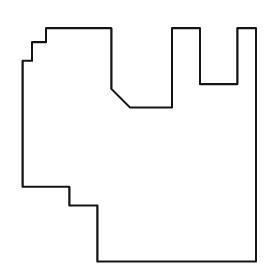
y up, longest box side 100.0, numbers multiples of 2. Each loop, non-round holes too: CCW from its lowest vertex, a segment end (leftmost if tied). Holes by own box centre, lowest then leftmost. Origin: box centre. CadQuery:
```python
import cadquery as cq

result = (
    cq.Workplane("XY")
    .moveTo(-18.0, -50.0)
    .lineTo(50.0, -50.0)
    .lineTo(50.0, 50.0)
    .lineTo(42.0, 50.0)
    .lineTo(42.0, 26.0)
    .lineTo(26.0, 26.0)
    .lineTo(26.0, 50.0)
    .lineTo(14.0, 50.0)
    .lineTo(14.0, 16.0)
    .lineTo(-4.0, 16.0)
    .lineTo(-12.0, 24.0)
    .lineTo(-12.0, 50.0)
    .lineTo(-40.0, 50.0)
    .lineTo(-40.0, 44.0)
    .lineTo(-46.0, 44.0)
    .lineTo(-46.0, 36.0)
    .lineTo(-50.0, 36.0)
    .lineTo(-50.0, -18.0)
    .lineTo(-30.0, -18.0)
    .lineTo(-30.0, -26.0)
    .lineTo(-18.0, -26.0)
    .close()
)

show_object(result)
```